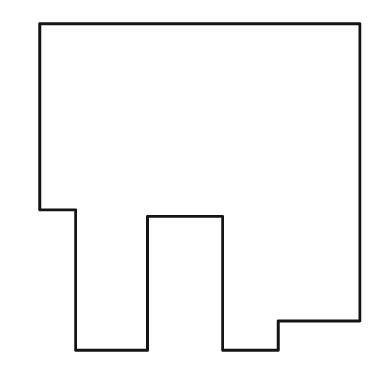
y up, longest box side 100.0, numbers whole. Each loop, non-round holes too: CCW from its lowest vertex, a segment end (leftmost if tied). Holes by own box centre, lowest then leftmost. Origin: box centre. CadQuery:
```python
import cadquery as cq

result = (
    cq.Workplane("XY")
    .moveTo(-38.0, -50.0)
    .lineTo(-16.0, -50.0)
    .lineTo(-16.0, -9.0)
    .lineTo(7.0, -9.0)
    .lineTo(7.0, -50.0)
    .lineTo(24.0, -50.0)
    .lineTo(24.0, -41.0)
    .lineTo(49.0, -41.0)
    .lineTo(49.0, 50.0)
    .lineTo(-49.0, 50.0)
    .lineTo(-49.0, -7.0)
    .lineTo(-38.0, -7.0)
    .close()
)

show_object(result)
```